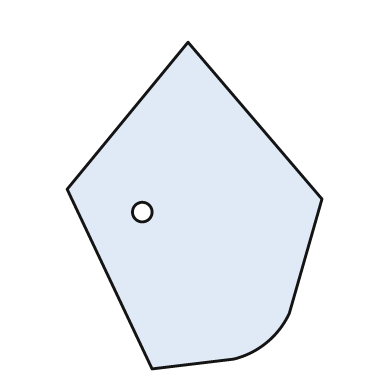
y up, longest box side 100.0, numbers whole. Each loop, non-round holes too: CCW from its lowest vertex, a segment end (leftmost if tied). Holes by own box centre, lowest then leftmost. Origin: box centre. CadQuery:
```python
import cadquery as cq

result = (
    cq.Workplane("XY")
    .moveTo(-13.0, -50.0)
    .lineTo(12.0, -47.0)
    .threePointArc((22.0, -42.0), (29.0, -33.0))
    .lineTo(39.0, 2.0)
    .lineTo(-2.0, 50.0)
    .lineTo(-39.0, 5.0)
    .close()
    .moveTo(-16.0, -2.0)
    .circle(3.0)
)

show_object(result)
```